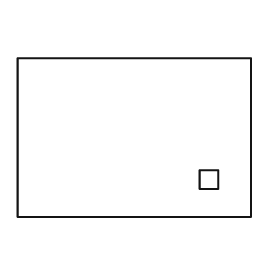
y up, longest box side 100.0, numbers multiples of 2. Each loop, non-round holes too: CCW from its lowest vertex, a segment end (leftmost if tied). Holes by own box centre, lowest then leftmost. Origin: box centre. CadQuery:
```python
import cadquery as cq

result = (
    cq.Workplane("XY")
    .moveTo(-50.0, -34.0)
    .lineTo(50.0, -34.0)
    .lineTo(50.0, 34.0)
    .lineTo(-50.0, 34.0)
    .close()
    .moveTo(28.0, -22.0)
    .lineTo(36.0, -22.0)
    .lineTo(36.0, -14.0)
    .lineTo(28.0, -14.0)
    .close()
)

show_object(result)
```